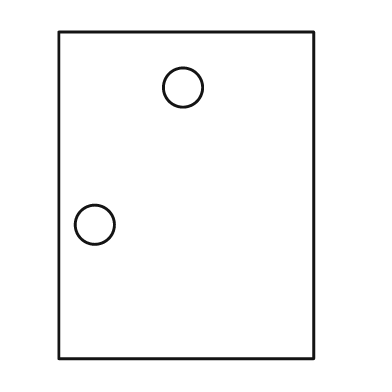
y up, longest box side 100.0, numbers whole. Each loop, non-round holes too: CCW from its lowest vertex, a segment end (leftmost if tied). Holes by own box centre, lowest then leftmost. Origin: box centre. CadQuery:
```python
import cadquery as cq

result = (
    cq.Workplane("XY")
    .moveTo(-39.0, -50.0)
    .lineTo(39.0, -50.0)
    .lineTo(39.0, 50.0)
    .lineTo(-39.0, 50.0)
    .close()
    .moveTo(-28.0, -9.0)
    .circle(6.0)
    .moveTo(-1.0, 33.0)
    .circle(6.0)
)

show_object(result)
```